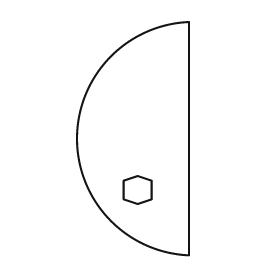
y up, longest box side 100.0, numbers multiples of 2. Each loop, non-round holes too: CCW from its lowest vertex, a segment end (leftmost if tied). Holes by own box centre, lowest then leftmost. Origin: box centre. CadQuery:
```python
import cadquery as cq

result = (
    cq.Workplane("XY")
    .moveTo(24.0, -50.0)
    .lineTo(24.0, 50.0)
    .threePointArc((-24.0, 0.0), (24.0, -50.0))
    .close()
    .moveTo(2.0, -28.0)
    .lineTo(8.0, -26.0)
    .lineTo(8.0, -18.0)
    .lineTo(2.0, -16.0)
    .lineTo(-4.0, -18.0)
    .lineTo(-4.0, -26.0)
    .close()
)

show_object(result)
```